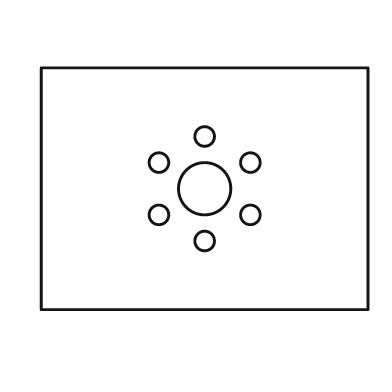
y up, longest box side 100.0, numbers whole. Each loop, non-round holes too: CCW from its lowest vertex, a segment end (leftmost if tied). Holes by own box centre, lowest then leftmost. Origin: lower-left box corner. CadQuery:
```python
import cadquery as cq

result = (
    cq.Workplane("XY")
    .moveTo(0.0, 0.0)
    .lineTo(100.0, 0.0)
    .lineTo(100.0, 74.0)
    .lineTo(0.0, 74.0)
    .close()
    .moveTo(50.0, 21.0)
    .circle(3.0)
    .moveTo(36.0, 29.0)
    .circle(3.0)
    .moveTo(64.0, 29.0)
    .circle(3.0)
    .moveTo(50.0, 37.0)
    .circle(8.0)
    .moveTo(36.0, 45.0)
    .circle(3.0)
    .moveTo(64.0, 45.0)
    .circle(3.0)
    .moveTo(50.0, 53.0)
    .circle(3.0)
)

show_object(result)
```